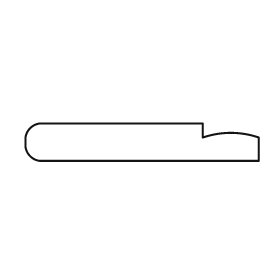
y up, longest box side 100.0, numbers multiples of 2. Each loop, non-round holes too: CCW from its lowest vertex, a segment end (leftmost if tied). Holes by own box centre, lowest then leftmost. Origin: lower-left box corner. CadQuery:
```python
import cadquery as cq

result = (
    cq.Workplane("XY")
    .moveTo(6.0, 0.0)
    .lineTo(100.0, 0.0)
    .lineTo(100.0, 10.0)
    .threePointArc((88.0, 12.0), (76.0, 10.0))
    .lineTo(76.0, 16.0)
    .lineTo(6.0, 16.0)
    .threePointArc((2.0, 14.0), (0.0, 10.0))
    .lineTo(0.0, 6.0)
    .threePointArc((2.0, 2.0), (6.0, 0.0))
    .close()
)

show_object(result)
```